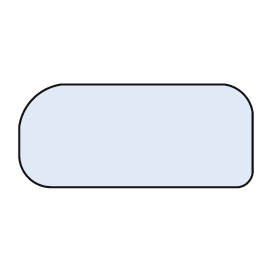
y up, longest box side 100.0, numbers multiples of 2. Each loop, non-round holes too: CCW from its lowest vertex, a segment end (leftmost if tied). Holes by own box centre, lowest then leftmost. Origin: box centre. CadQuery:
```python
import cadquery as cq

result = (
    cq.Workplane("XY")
    .moveTo(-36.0, -22.0)
    .lineTo(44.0, -22.0)
    .threePointArc((48.0, -20.0), (50.0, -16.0))
    .lineTo(50.0, 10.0)
    .threePointArc((46.0, 18.0), (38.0, 22.0))
    .lineTo(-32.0, 22.0)
    .threePointArc((-44.0, 16.0), (-50.0, 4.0))
    .lineTo(-50.0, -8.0)
    .threePointArc((-46.0, -18.0), (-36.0, -22.0))
    .close()
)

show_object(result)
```